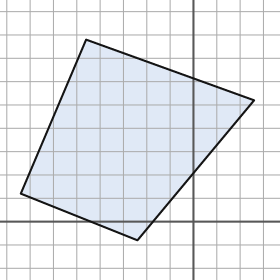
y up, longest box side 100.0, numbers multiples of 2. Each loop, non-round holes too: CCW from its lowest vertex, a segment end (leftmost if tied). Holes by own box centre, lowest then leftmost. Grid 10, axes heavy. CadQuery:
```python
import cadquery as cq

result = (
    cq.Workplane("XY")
    .moveTo(-24.0, -8.0)
    .lineTo(26.0, 52.0)
    .lineTo(-46.0, 78.0)
    .lineTo(-74.0, 12.0)
    .close()
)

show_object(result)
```